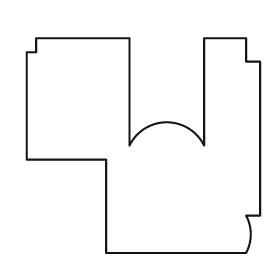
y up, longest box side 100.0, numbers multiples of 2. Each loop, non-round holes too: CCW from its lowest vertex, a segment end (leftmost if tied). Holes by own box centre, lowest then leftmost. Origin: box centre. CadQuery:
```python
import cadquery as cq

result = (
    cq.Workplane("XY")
    .moveTo(-16.0, -46.0)
    .lineTo(44.0, -46.0)
    .threePointArc((46.0, -38.0), (44.0, -30.0))
    .lineTo(50.0, -30.0)
    .lineTo(50.0, 36.0)
    .lineTo(44.0, 36.0)
    .lineTo(44.0, 46.0)
    .lineTo(26.0, 46.0)
    .lineTo(26.0, 0.0)
    .threePointArc((10.0, 10.0), (-6.0, 0.0))
    .lineTo(-6.0, 46.0)
    .lineTo(-46.0, 46.0)
    .lineTo(-46.0, 40.0)
    .lineTo(-50.0, 40.0)
    .lineTo(-50.0, -6.0)
    .lineTo(-16.0, -6.0)
    .close()
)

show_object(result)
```